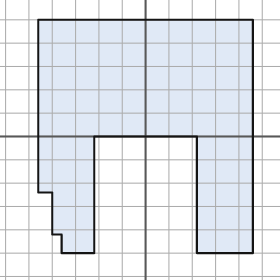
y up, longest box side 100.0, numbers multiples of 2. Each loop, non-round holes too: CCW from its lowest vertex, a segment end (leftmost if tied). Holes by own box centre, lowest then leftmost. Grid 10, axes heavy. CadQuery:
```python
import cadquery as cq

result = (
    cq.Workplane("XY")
    .moveTo(-36.0, -50.0)
    .lineTo(-22.0, -50.0)
    .lineTo(-22.0, 0.0)
    .lineTo(22.0, 0.0)
    .lineTo(22.0, -50.0)
    .lineTo(46.0, -50.0)
    .lineTo(46.0, 50.0)
    .lineTo(-46.0, 50.0)
    .lineTo(-46.0, -24.0)
    .lineTo(-40.0, -24.0)
    .lineTo(-40.0, -42.0)
    .lineTo(-36.0, -42.0)
    .close()
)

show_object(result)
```